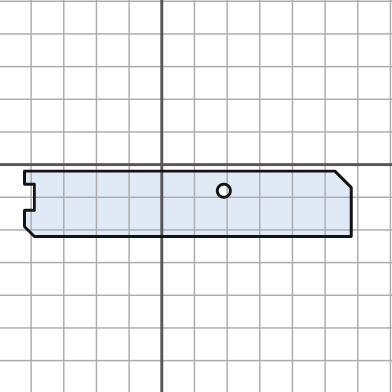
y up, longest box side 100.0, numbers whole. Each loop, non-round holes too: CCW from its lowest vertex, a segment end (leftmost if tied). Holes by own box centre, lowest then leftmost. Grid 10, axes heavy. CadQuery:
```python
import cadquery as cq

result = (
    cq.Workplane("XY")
    .moveTo(-39.0, -22.0)
    .lineTo(58.0, -22.0)
    .lineTo(58.0, -7.0)
    .lineTo(53.0, -2.0)
    .lineTo(-42.0, -2.0)
    .lineTo(-42.0, -6.0)
    .lineTo(-39.0, -6.0)
    .lineTo(-39.0, -14.0)
    .lineTo(-42.0, -14.0)
    .lineTo(-42.0, -19.0)
    .close()
    .moveTo(19.0, -8.0)
    .circle(2.0)
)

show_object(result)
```